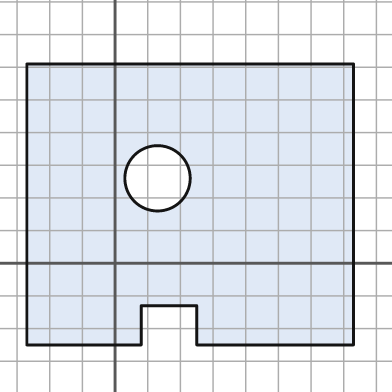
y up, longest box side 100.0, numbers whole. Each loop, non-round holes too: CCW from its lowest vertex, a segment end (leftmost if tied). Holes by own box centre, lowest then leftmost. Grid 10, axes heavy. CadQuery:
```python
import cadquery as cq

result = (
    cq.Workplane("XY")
    .moveTo(-27.0, -25.0)
    .lineTo(8.0, -25.0)
    .lineTo(8.0, -13.0)
    .lineTo(25.0, -13.0)
    .lineTo(25.0, -25.0)
    .lineTo(73.0, -25.0)
    .lineTo(73.0, 61.0)
    .lineTo(-27.0, 61.0)
    .close()
    .moveTo(13.0, 26.0)
    .circle(10.0)
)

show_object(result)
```